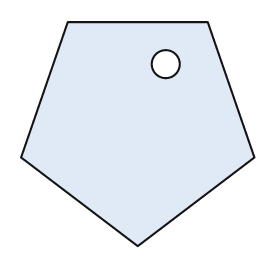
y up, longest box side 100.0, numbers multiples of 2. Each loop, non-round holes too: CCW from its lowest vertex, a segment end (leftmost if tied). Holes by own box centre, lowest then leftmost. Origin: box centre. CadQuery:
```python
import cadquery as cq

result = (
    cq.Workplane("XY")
    .moveTo(0.0, -48.0)
    .lineTo(50.0, -10.0)
    .lineTo(30.0, 48.0)
    .lineTo(-30.0, 48.0)
    .lineTo(-50.0, -10.0)
    .close()
    .moveTo(12.0, 30.0)
    .circle(6.0)
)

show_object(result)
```